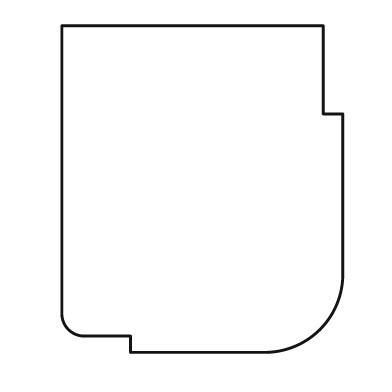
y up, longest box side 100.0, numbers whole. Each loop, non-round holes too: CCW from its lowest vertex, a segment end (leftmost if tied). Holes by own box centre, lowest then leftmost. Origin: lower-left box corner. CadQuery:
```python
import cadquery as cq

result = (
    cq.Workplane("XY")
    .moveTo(21.0, 0.0)
    .lineTo(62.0, 0.0)
    .threePointArc((79.0, 7.0), (86.0, 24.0))
    .lineTo(86.0, 73.0)
    .lineTo(80.0, 73.0)
    .lineTo(80.0, 100.0)
    .lineTo(0.0, 100.0)
    .lineTo(0.0, 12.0)
    .threePointArc((2.0, 7.0), (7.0, 5.0))
    .lineTo(21.0, 5.0)
    .close()
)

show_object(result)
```